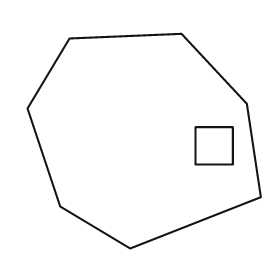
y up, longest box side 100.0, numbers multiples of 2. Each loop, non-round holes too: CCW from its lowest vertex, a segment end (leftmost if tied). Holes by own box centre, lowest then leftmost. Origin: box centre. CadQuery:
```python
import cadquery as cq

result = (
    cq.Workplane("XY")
    .moveTo(-6.0, -46.0)
    .lineTo(50.0, -24.0)
    .lineTo(44.0, 16.0)
    .lineTo(16.0, 46.0)
    .lineTo(-32.0, 44.0)
    .lineTo(-50.0, 14.0)
    .lineTo(-36.0, -28.0)
    .close()
    .moveTo(22.0, -10.0)
    .lineTo(38.0, -10.0)
    .lineTo(38.0, 6.0)
    .lineTo(22.0, 6.0)
    .close()
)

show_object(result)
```